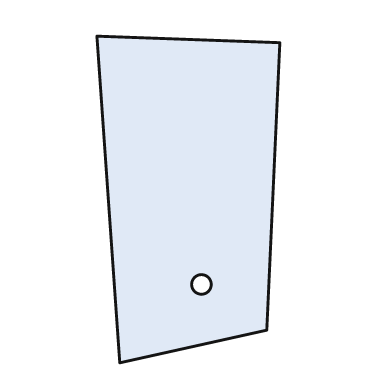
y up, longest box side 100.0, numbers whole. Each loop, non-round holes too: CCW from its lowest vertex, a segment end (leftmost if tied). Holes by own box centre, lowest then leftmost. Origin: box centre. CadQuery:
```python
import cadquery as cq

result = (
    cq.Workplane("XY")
    .moveTo(-21.0, -50.0)
    .lineTo(24.0, -40.0)
    .lineTo(28.0, 48.0)
    .lineTo(-28.0, 50.0)
    .close()
    .moveTo(4.0, -26.0)
    .circle(3.0)
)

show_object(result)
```